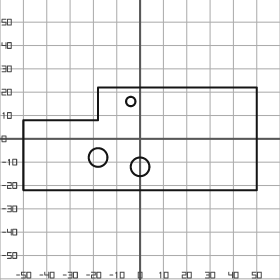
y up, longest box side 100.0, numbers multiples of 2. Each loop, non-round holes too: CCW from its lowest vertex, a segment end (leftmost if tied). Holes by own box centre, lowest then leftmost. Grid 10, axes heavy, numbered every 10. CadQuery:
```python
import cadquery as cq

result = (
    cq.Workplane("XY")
    .moveTo(-50.0, -22.0)
    .lineTo(50.0, -22.0)
    .lineTo(50.0, 22.0)
    .lineTo(-18.0, 22.0)
    .lineTo(-18.0, 8.0)
    .lineTo(-50.0, 8.0)
    .close()
    .moveTo(0.0, -12.0)
    .circle(4.0)
    .moveTo(-18.0, -8.0)
    .circle(4.0)
    .moveTo(-4.0, 16.0)
    .circle(2.0)
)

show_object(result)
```